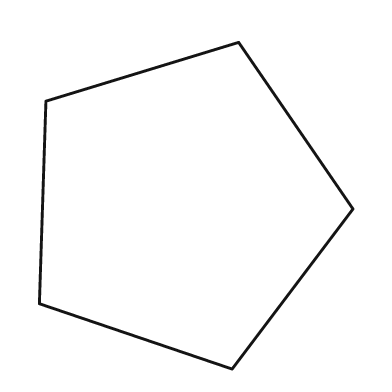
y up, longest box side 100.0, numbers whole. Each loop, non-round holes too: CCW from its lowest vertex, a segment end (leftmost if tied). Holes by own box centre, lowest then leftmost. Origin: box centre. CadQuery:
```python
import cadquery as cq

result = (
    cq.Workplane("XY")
    .moveTo(11.0, -50.0)
    .lineTo(48.0, -1.0)
    .lineTo(13.0, 50.0)
    .lineTo(-46.0, 32.0)
    .lineTo(-48.0, -30.0)
    .close()
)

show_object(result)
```